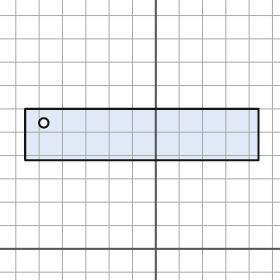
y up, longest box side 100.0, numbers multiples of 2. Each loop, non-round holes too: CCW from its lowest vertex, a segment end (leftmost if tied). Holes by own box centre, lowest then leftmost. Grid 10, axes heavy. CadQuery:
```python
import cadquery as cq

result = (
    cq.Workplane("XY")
    .moveTo(-56.0, 38.0)
    .lineTo(44.0, 38.0)
    .lineTo(44.0, 60.0)
    .lineTo(-56.0, 60.0)
    .close()
    .moveTo(-48.0, 54.0)
    .circle(2.0)
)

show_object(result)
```